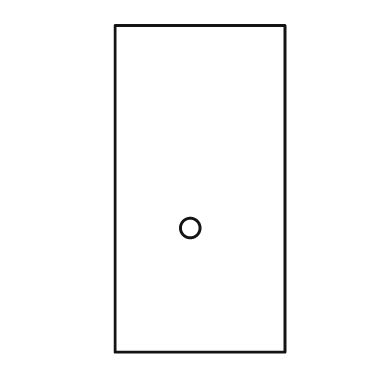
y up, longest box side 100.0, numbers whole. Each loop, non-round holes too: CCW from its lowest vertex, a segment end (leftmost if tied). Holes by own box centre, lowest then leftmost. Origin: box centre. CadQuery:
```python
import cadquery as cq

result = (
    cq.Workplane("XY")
    .moveTo(-26.0, -50.0)
    .lineTo(26.0, -50.0)
    .lineTo(26.0, 50.0)
    .lineTo(-26.0, 50.0)
    .close()
    .moveTo(-3.0, -12.0)
    .circle(3.0)
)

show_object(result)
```